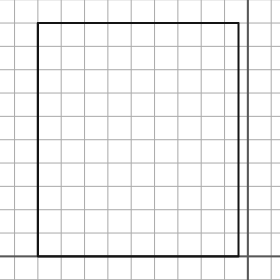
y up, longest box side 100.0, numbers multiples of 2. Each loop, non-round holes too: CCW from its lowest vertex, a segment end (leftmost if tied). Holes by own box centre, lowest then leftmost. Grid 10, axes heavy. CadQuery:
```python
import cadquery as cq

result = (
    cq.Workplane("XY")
    .moveTo(-90.0, 0.0)
    .lineTo(-4.0, 0.0)
    .lineTo(-4.0, 100.0)
    .lineTo(-90.0, 100.0)
    .close()
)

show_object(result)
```